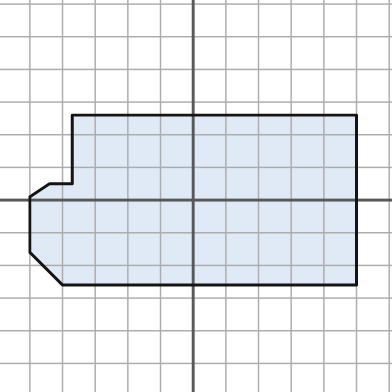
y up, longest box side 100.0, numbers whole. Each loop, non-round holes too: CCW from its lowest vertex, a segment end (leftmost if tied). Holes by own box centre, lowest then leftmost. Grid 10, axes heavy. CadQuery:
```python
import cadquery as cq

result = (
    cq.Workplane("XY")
    .moveTo(-40.0, -26.0)
    .lineTo(50.0, -26.0)
    .lineTo(50.0, 26.0)
    .lineTo(-37.0, 26.0)
    .lineTo(-37.0, 5.0)
    .lineTo(-44.0, 5.0)
    .lineTo(-50.0, 1.0)
    .lineTo(-50.0, -16.0)
    .close()
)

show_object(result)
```